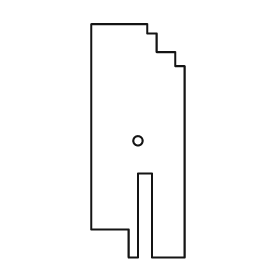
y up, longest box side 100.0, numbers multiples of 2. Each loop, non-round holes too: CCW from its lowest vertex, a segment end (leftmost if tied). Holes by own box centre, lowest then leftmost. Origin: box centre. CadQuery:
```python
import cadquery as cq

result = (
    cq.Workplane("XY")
    .moveTo(-4.0, -50.0)
    .lineTo(0.0, -50.0)
    .lineTo(0.0, -14.0)
    .lineTo(6.0, -14.0)
    .lineTo(6.0, -50.0)
    .lineTo(20.0, -50.0)
    .lineTo(20.0, 32.0)
    .lineTo(16.0, 32.0)
    .lineTo(16.0, 38.0)
    .lineTo(8.0, 38.0)
    .lineTo(8.0, 46.0)
    .lineTo(4.0, 46.0)
    .lineTo(4.0, 50.0)
    .lineTo(-20.0, 50.0)
    .lineTo(-20.0, -38.0)
    .lineTo(-4.0, -38.0)
    .close()
    .moveTo(0.0, 0.0)
    .circle(2.0)
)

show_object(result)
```